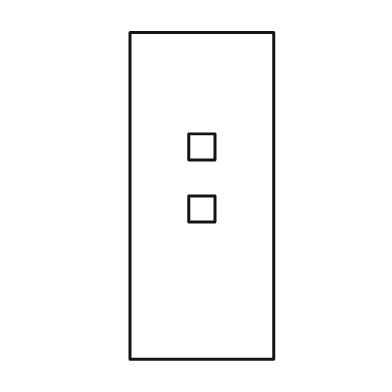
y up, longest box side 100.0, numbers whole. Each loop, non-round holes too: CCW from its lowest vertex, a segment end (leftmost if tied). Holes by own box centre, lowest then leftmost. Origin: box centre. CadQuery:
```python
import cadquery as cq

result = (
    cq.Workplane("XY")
    .moveTo(-22.0, -50.0)
    .lineTo(22.0, -50.0)
    .lineTo(22.0, 50.0)
    .lineTo(-22.0, 50.0)
    .close()
    .moveTo(-4.0, -8.0)
    .lineTo(4.0, -8.0)
    .lineTo(4.0, 0.0)
    .lineTo(-4.0, 0.0)
    .close()
    .moveTo(-4.0, 11.0)
    .lineTo(4.0, 11.0)
    .lineTo(4.0, 19.0)
    .lineTo(-4.0, 19.0)
    .close()
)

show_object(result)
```